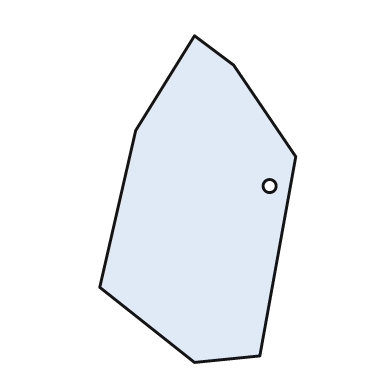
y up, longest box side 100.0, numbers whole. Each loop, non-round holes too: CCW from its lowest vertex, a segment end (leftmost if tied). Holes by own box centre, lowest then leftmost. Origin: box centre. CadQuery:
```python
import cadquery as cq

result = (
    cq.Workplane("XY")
    .moveTo(-1.0, -50.0)
    .lineTo(19.0, -48.0)
    .lineTo(30.0, 13.0)
    .lineTo(11.0, 41.0)
    .lineTo(-1.0, 50.0)
    .lineTo(-19.0, 21.0)
    .lineTo(-30.0, -27.0)
    .close()
    .moveTo(22.0, 4.0)
    .circle(2.0)
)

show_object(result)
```